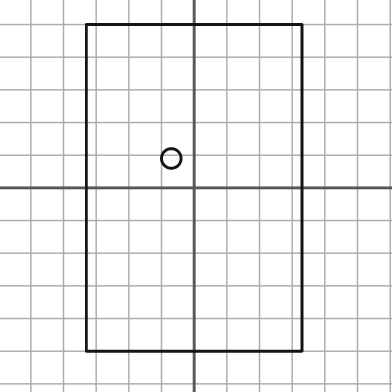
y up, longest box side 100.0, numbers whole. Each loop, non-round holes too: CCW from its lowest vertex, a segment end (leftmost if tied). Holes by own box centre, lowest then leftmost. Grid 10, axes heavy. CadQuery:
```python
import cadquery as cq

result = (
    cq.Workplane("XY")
    .moveTo(-33.0, -50.0)
    .lineTo(33.0, -50.0)
    .lineTo(33.0, 50.0)
    .lineTo(-33.0, 50.0)
    .close()
    .moveTo(-7.0, 9.0)
    .circle(3.0)
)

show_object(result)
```